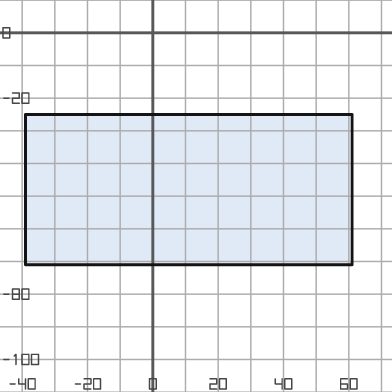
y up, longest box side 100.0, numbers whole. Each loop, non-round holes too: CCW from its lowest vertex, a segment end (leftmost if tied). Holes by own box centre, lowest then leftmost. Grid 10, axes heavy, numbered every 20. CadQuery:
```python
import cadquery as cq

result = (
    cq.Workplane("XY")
    .moveTo(-39.0, -71.0)
    .lineTo(61.0, -71.0)
    .lineTo(61.0, -25.0)
    .lineTo(-39.0, -25.0)
    .close()
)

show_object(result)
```